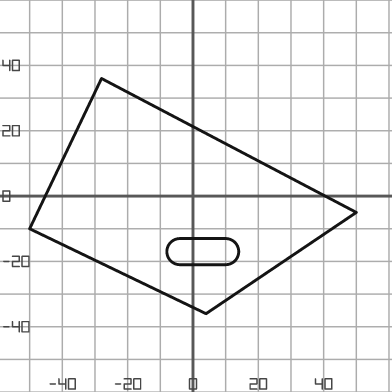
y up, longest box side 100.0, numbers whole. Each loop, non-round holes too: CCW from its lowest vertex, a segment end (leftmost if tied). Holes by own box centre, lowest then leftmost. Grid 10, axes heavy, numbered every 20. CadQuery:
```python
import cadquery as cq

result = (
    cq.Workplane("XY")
    .moveTo(4.0, -36.0)
    .lineTo(50.0, -5.0)
    .lineTo(-28.0, 36.0)
    .lineTo(-50.0, -10.0)
    .close()
    .moveTo(-4.0, -21.0)
    .lineTo(10.0, -21.0)
    .threePointArc((14.0, -17.0), (10.0, -13.0))
    .lineTo(-4.0, -13.0)
    .threePointArc((-8.0, -17.0), (-4.0, -21.0))
    .close()
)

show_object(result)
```